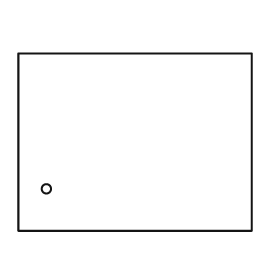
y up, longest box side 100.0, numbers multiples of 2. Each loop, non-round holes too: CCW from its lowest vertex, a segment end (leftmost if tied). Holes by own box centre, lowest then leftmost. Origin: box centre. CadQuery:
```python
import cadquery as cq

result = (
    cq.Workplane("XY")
    .moveTo(-50.0, -38.0)
    .lineTo(50.0, -38.0)
    .lineTo(50.0, 38.0)
    .lineTo(-50.0, 38.0)
    .close()
    .moveTo(-38.0, -20.0)
    .circle(2.0)
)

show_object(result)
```